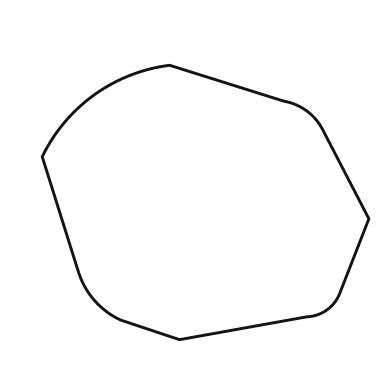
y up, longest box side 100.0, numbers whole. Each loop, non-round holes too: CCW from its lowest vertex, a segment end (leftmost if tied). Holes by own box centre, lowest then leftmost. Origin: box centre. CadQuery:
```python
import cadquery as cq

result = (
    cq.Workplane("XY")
    .moveTo(-8.0, -42.0)
    .lineTo(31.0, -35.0)
    .threePointArc((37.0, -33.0), (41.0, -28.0))
    .lineTo(50.0, -5.0)
    .lineTo(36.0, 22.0)
    .threePointArc((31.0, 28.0), (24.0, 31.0))
    .lineTo(-11.0, 42.0)
    .threePointArc((-34.0, 33.0), (-50.0, 14.0))
    .lineTo(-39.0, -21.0)
    .threePointArc((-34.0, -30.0), (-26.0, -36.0))
    .close()
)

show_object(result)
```